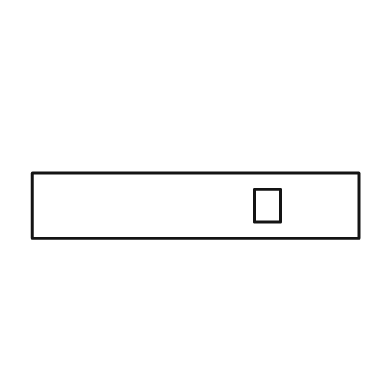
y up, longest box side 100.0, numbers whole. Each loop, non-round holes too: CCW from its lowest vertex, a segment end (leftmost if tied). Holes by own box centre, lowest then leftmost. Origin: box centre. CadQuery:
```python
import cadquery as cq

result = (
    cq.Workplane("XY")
    .moveTo(-50.0, -10.0)
    .lineTo(50.0, -10.0)
    .lineTo(50.0, 10.0)
    .lineTo(-50.0, 10.0)
    .close()
    .moveTo(18.0, -5.0)
    .lineTo(26.0, -5.0)
    .lineTo(26.0, 5.0)
    .lineTo(18.0, 5.0)
    .close()
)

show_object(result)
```